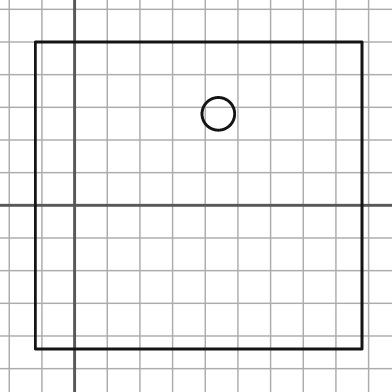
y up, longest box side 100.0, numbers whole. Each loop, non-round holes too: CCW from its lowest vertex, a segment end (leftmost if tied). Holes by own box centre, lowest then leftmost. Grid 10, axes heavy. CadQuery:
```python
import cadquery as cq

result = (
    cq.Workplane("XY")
    .moveTo(-12.0, -44.0)
    .lineTo(88.0, -44.0)
    .lineTo(88.0, 50.0)
    .lineTo(-12.0, 50.0)
    .close()
    .moveTo(44.0, 28.0)
    .circle(5.0)
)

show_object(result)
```